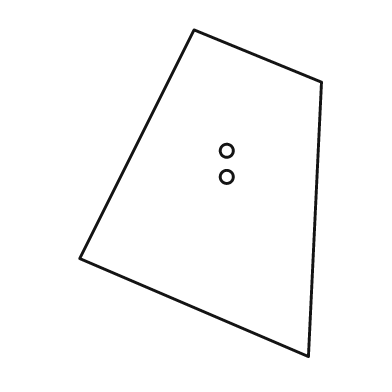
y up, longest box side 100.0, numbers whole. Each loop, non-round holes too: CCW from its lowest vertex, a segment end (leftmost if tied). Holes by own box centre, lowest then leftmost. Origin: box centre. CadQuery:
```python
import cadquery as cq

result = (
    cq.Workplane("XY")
    .moveTo(33.0, -50.0)
    .lineTo(37.0, 34.0)
    .lineTo(-2.0, 50.0)
    .lineTo(-37.0, -20.0)
    .close()
    .moveTo(8.0, 5.0)
    .circle(2.0)
    .moveTo(8.0, 13.0)
    .circle(2.0)
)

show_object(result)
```